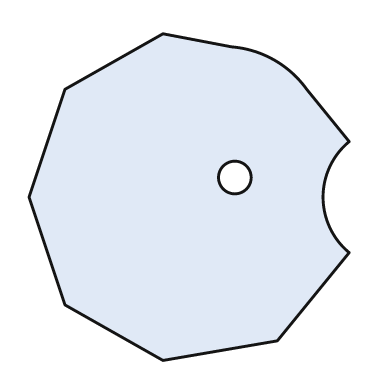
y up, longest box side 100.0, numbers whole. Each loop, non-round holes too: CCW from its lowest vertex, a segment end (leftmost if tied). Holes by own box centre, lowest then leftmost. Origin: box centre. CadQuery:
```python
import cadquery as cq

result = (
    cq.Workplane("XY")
    .moveTo(-8.0, -50.0)
    .lineTo(27.0, -44.0)
    .lineTo(49.0, -17.0)
    .threePointArc((41.0, 0.0), (49.0, 17.0))
    .lineTo(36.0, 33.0)
    .threePointArc((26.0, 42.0), (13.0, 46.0))
    .lineTo(-8.0, 50.0)
    .lineTo(-38.0, 33.0)
    .lineTo(-49.0, 0.0)
    .lineTo(-38.0, -33.0)
    .close()
    .moveTo(14.0, 6.0)
    .circle(5.0)
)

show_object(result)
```